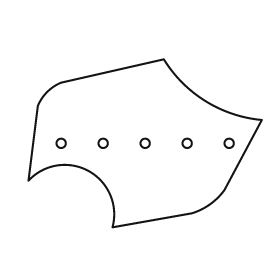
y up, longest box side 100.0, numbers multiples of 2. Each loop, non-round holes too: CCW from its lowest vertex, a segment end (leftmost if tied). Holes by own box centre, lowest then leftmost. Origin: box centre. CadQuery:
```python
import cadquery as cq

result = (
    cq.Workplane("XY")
    .moveTo(-14.0, -36.0)
    .lineTo(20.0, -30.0)
    .threePointArc((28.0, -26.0), (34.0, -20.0))
    .lineTo(50.0, 10.0)
    .threePointArc((26.0, 18.0), (8.0, 36.0))
    .lineTo(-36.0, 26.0)
    .threePointArc((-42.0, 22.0), (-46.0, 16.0))
    .lineTo(-50.0, -16.0)
    .threePointArc((-24.0, -12.0), (-14.0, -36.0))
    .close()
    .moveTo(-36.0, 0.0)
    .circle(2.0)
    .moveTo(-18.0, 0.0)
    .circle(2.0)
    .moveTo(0.0, 0.0)
    .circle(2.0)
    .moveTo(18.0, 0.0)
    .circle(2.0)
    .moveTo(36.0, 0.0)
    .circle(2.0)
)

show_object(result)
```